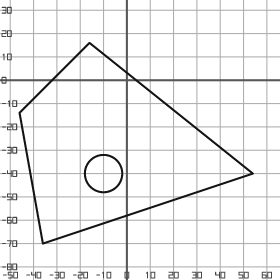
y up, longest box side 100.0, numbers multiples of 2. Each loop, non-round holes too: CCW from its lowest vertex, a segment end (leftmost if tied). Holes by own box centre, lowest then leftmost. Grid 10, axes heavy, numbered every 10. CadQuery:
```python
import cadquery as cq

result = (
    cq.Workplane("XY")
    .moveTo(-36.0, -70.0)
    .lineTo(54.0, -40.0)
    .lineTo(-16.0, 16.0)
    .lineTo(-46.0, -14.0)
    .close()
    .moveTo(-10.0, -40.0)
    .circle(8.0)
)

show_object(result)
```